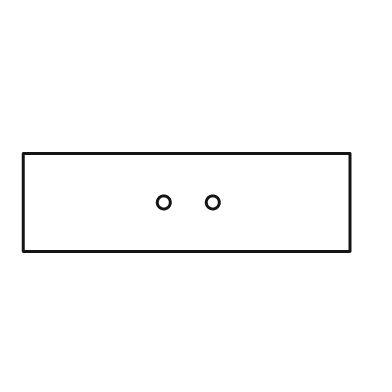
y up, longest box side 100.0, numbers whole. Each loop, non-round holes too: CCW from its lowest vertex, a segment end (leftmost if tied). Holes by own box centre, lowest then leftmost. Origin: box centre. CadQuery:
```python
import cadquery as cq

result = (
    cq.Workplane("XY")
    .moveTo(-50.0, -15.0)
    .lineTo(50.0, -15.0)
    .lineTo(50.0, 15.0)
    .lineTo(-50.0, 15.0)
    .close()
    .moveTo(-7.0, 0.0)
    .circle(2.0)
    .moveTo(8.0, 0.0)
    .circle(2.0)
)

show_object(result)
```